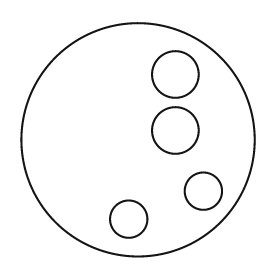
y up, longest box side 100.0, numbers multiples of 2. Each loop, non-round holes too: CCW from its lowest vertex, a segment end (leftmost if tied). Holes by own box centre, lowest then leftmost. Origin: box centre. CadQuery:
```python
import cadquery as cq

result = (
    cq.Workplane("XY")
    .moveTo(0.0, 0.0)
    .circle(50.0)
    .moveTo(-4.0, -34.0)
    .circle(8.0)
    .moveTo(28.0, -22.0)
    .circle(8.0)
    .moveTo(16.0, 4.0)
    .circle(10.0)
    .moveTo(16.0, 28.0)
    .circle(10.0)
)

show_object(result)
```